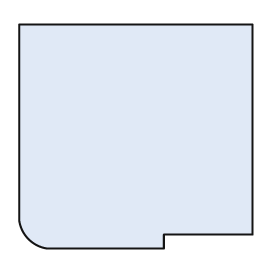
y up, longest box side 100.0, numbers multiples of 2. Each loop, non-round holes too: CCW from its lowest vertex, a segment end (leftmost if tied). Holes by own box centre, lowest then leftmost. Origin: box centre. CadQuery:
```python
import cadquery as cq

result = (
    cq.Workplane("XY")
    .moveTo(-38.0, -48.0)
    .lineTo(12.0, -48.0)
    .lineTo(12.0, -42.0)
    .lineTo(50.0, -42.0)
    .lineTo(50.0, 48.0)
    .lineTo(-50.0, 48.0)
    .lineTo(-50.0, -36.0)
    .threePointArc((-46.0, -44.0), (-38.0, -48.0))
    .close()
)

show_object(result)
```